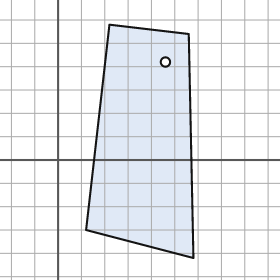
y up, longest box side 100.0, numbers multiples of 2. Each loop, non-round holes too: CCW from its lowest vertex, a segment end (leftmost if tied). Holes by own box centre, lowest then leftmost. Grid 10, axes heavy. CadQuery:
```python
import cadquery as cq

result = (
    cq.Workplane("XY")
    .moveTo(58.0, -42.0)
    .lineTo(56.0, 54.0)
    .lineTo(22.0, 58.0)
    .lineTo(12.0, -30.0)
    .close()
    .moveTo(46.0, 42.0)
    .circle(2.0)
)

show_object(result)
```